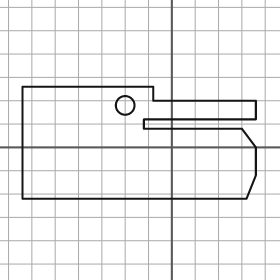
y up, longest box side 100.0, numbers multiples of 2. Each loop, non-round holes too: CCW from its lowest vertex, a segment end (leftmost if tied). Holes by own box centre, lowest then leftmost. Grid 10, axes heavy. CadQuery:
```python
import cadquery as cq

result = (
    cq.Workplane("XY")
    .moveTo(-64.0, -22.0)
    .lineTo(32.0, -22.0)
    .lineTo(36.0, -12.0)
    .lineTo(36.0, 0.0)
    .lineTo(30.0, 8.0)
    .lineTo(-12.0, 8.0)
    .lineTo(-12.0, 12.0)
    .lineTo(36.0, 12.0)
    .lineTo(36.0, 20.0)
    .lineTo(-8.0, 20.0)
    .lineTo(-8.0, 26.0)
    .lineTo(-64.0, 26.0)
    .close()
    .moveTo(-20.0, 18.0)
    .circle(4.0)
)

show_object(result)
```